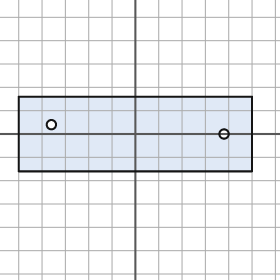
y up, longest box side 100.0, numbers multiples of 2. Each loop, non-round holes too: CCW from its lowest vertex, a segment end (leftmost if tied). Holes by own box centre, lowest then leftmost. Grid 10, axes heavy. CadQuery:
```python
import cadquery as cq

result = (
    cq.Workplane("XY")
    .moveTo(-50.0, -16.0)
    .lineTo(50.0, -16.0)
    .lineTo(50.0, 16.0)
    .lineTo(-50.0, 16.0)
    .close()
    .moveTo(38.0, 0.0)
    .circle(2.0)
    .moveTo(-36.0, 4.0)
    .circle(2.0)
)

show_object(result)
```